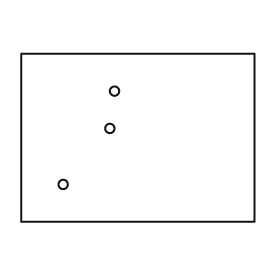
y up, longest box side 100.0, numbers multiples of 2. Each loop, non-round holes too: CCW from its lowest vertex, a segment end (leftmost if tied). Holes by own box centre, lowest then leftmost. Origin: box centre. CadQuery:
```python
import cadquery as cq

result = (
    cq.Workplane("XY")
    .moveTo(-50.0, -36.0)
    .lineTo(50.0, -36.0)
    .lineTo(50.0, 36.0)
    .lineTo(-50.0, 36.0)
    .close()
    .moveTo(-32.0, -20.0)
    .circle(2.0)
    .moveTo(-12.0, 4.0)
    .circle(2.0)
    .moveTo(-10.0, 20.0)
    .circle(2.0)
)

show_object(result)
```